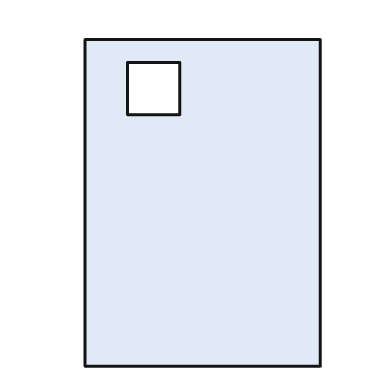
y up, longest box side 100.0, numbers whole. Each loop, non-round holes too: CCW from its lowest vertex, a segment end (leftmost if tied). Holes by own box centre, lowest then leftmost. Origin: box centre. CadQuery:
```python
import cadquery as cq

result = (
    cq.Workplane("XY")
    .moveTo(-36.0, -50.0)
    .lineTo(36.0, -50.0)
    .lineTo(36.0, 50.0)
    .lineTo(-36.0, 50.0)
    .close()
    .moveTo(-23.0, 27.0)
    .lineTo(-7.0, 27.0)
    .lineTo(-7.0, 43.0)
    .lineTo(-23.0, 43.0)
    .close()
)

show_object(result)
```